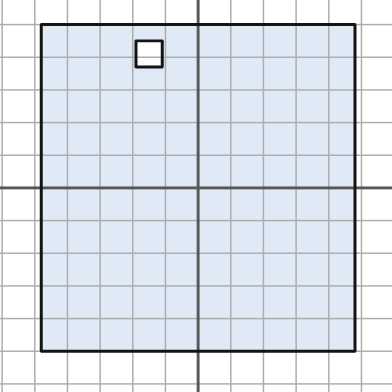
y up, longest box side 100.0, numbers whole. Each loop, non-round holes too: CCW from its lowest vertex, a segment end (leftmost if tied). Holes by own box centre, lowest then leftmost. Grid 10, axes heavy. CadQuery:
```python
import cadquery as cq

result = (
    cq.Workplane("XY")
    .moveTo(-48.0, -50.0)
    .lineTo(48.0, -50.0)
    .lineTo(48.0, 50.0)
    .lineTo(-48.0, 50.0)
    .close()
    .moveTo(-19.0, 37.0)
    .lineTo(-11.0, 37.0)
    .lineTo(-11.0, 45.0)
    .lineTo(-19.0, 45.0)
    .close()
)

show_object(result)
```